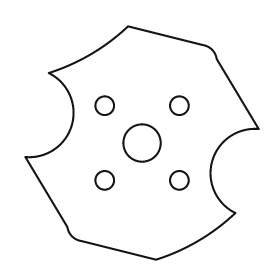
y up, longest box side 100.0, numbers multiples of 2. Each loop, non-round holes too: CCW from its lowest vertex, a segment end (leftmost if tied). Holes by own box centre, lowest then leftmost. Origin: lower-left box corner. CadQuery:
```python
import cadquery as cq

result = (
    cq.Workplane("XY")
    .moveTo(56.0, 0.0)
    .threePointArc((74.0, 8.0), (90.0, 20.0))
    .threePointArc((80.0, 42.0), (100.0, 56.0))
    .lineTo(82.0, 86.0)
    .threePointArc((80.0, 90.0), (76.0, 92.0))
    .lineTo(44.0, 100.0)
    .threePointArc((28.0, 88.0), (10.0, 80.0))
    .threePointArc((20.0, 58.0), (0.0, 44.0))
    .lineTo(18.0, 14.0)
    .threePointArc((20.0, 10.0), (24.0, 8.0))
    .close()
    .moveTo(34.0, 34.0)
    .circle(4.0)
    .moveTo(66.0, 34.0)
    .circle(4.0)
    .moveTo(50.0, 50.0)
    .circle(8.0)
    .moveTo(34.0, 66.0)
    .circle(4.0)
    .moveTo(66.0, 66.0)
    .circle(4.0)
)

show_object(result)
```